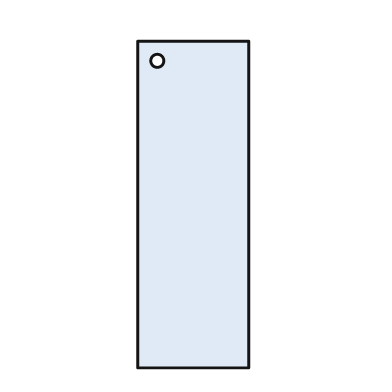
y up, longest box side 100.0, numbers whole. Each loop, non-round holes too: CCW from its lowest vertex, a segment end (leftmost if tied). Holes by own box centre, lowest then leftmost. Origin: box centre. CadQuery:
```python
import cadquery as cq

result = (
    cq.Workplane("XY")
    .moveTo(-17.0, -50.0)
    .lineTo(17.0, -50.0)
    .lineTo(17.0, 50.0)
    .lineTo(-17.0, 50.0)
    .close()
    .moveTo(-11.0, 44.0)
    .circle(2.0)
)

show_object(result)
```